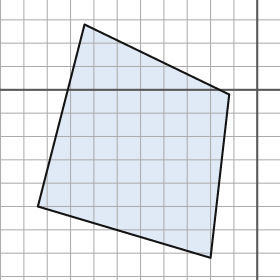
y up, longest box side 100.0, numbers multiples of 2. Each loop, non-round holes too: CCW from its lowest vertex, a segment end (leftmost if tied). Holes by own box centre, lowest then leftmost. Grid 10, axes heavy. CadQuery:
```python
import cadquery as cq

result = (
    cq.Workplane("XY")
    .moveTo(-20.0, -72.0)
    .lineTo(-12.0, -2.0)
    .lineTo(-74.0, 28.0)
    .lineTo(-94.0, -50.0)
    .close()
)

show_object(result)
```